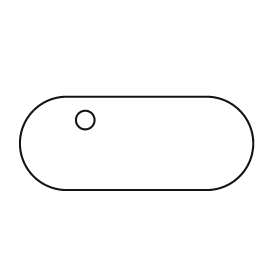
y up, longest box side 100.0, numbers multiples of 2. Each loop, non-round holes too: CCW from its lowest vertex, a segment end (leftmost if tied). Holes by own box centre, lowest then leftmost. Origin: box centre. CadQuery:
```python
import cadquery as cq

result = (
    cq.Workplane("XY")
    .moveTo(-30.0, -20.0)
    .lineTo(30.0, -20.0)
    .threePointArc((50.0, 0.0), (30.0, 20.0))
    .lineTo(-30.0, 20.0)
    .threePointArc((-50.0, 0.0), (-30.0, -20.0))
    .close()
    .moveTo(-22.0, 10.0)
    .circle(4.0)
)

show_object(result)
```